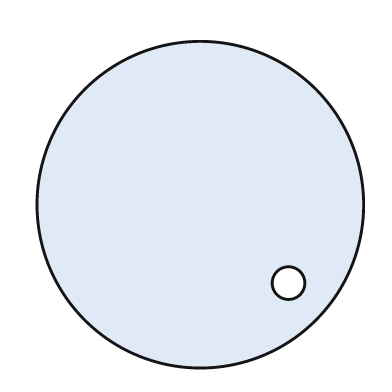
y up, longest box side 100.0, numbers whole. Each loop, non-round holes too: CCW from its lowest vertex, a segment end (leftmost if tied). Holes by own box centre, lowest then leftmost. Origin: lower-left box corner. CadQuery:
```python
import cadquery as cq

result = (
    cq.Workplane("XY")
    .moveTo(50.0, 50.0)
    .circle(50.0)
    .moveTo(77.0, 26.0)
    .circle(5.0)
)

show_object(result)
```